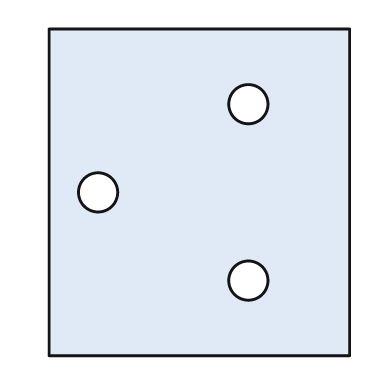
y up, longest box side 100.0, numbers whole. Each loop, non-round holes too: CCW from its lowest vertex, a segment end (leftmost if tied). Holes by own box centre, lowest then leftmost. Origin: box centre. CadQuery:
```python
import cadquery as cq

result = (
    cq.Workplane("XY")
    .moveTo(-46.0, -50.0)
    .lineTo(46.0, -50.0)
    .lineTo(46.0, 50.0)
    .lineTo(-46.0, 50.0)
    .close()
    .moveTo(15.0, -27.0)
    .circle(6.0)
    .moveTo(-31.0, 0.0)
    .circle(6.0)
    .moveTo(15.0, 27.0)
    .circle(6.0)
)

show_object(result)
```